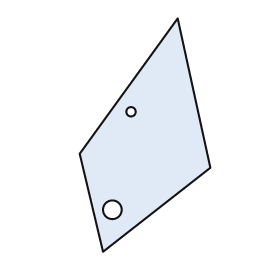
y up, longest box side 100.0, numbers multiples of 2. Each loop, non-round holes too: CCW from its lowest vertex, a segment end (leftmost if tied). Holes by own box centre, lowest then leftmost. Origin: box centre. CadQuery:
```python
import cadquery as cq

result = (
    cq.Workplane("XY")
    .moveTo(-18.0, -50.0)
    .lineTo(28.0, -14.0)
    .lineTo(14.0, 50.0)
    .lineTo(-28.0, -8.0)
    .close()
    .moveTo(-14.0, -32.0)
    .circle(4.0)
    .moveTo(-6.0, 10.0)
    .circle(2.0)
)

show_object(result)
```